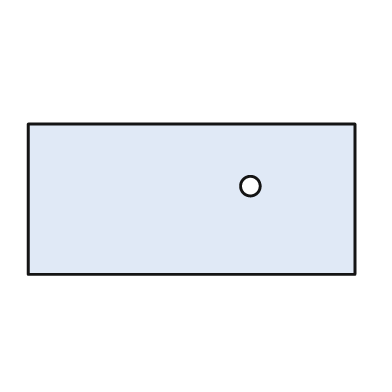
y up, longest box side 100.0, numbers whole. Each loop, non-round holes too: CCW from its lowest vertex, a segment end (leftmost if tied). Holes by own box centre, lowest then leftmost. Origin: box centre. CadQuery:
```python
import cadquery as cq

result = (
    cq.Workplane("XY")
    .moveTo(-50.0, -23.0)
    .lineTo(50.0, -23.0)
    .lineTo(50.0, 23.0)
    .lineTo(-50.0, 23.0)
    .close()
    .moveTo(18.0, 4.0)
    .circle(3.0)
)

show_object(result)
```